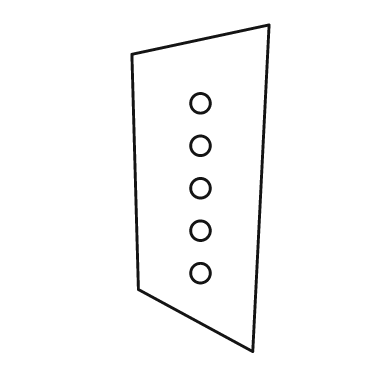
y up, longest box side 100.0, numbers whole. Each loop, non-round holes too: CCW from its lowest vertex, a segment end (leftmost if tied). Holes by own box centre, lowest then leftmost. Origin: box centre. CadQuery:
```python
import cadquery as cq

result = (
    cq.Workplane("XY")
    .moveTo(16.0, -50.0)
    .lineTo(21.0, 50.0)
    .lineTo(-21.0, 41.0)
    .lineTo(-19.0, -31.0)
    .close()
    .moveTo(0.0, -26.0)
    .circle(3.0)
    .moveTo(0.0, -13.0)
    .circle(3.0)
    .moveTo(0.0, 0.0)
    .circle(3.0)
    .moveTo(0.0, 13.0)
    .circle(3.0)
    .moveTo(0.0, 26.0)
    .circle(3.0)
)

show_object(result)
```